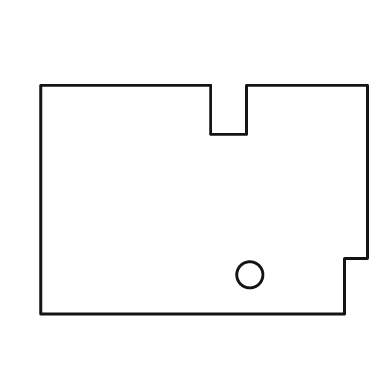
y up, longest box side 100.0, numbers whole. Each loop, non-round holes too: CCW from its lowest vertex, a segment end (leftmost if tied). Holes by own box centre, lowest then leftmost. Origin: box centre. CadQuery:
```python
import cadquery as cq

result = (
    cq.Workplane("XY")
    .moveTo(-50.0, -35.0)
    .lineTo(43.0, -35.0)
    .lineTo(43.0, -18.0)
    .lineTo(50.0, -18.0)
    .lineTo(50.0, 35.0)
    .lineTo(13.0, 35.0)
    .lineTo(13.0, 20.0)
    .lineTo(2.0, 20.0)
    .lineTo(2.0, 35.0)
    .lineTo(-50.0, 35.0)
    .close()
    .moveTo(14.0, -23.0)
    .circle(4.0)
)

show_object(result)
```